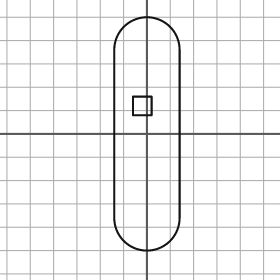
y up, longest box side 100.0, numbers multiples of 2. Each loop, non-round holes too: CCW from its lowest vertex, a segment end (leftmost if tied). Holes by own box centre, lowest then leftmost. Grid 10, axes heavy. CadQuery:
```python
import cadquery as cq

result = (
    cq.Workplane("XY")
    .moveTo(-14.0, -36.0)
    .threePointArc((0.0, -50.0), (14.0, -36.0))
    .lineTo(14.0, 36.0)
    .threePointArc((0.0, 50.0), (-14.0, 36.0))
    .close()
    .moveTo(-6.0, 8.0)
    .lineTo(2.0, 8.0)
    .lineTo(2.0, 16.0)
    .lineTo(-6.0, 16.0)
    .close()
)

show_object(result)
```